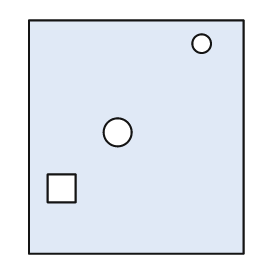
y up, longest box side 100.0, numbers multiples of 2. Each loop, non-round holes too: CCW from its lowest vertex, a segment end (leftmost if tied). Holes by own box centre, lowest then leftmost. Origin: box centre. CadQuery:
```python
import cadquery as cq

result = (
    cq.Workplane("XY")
    .moveTo(-46.0, -50.0)
    .lineTo(46.0, -50.0)
    .lineTo(46.0, 50.0)
    .lineTo(-46.0, 50.0)
    .close()
    .moveTo(-38.0, -28.0)
    .lineTo(-26.0, -28.0)
    .lineTo(-26.0, -16.0)
    .lineTo(-38.0, -16.0)
    .close()
    .moveTo(-8.0, 2.0)
    .circle(6.0)
    .moveTo(28.0, 40.0)
    .circle(4.0)
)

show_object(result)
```